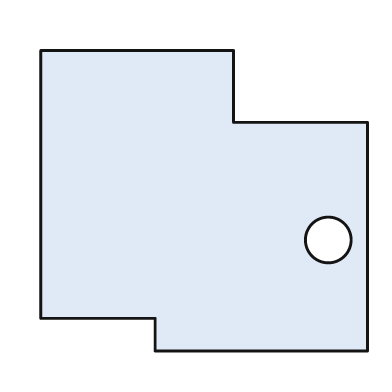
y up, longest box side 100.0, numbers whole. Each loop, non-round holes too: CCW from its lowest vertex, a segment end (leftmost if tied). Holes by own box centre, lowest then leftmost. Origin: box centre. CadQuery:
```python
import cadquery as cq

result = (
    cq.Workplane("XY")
    .moveTo(-15.0, -46.0)
    .lineTo(50.0, -46.0)
    .lineTo(50.0, 24.0)
    .lineTo(9.0, 24.0)
    .lineTo(9.0, 46.0)
    .lineTo(-50.0, 46.0)
    .lineTo(-50.0, -36.0)
    .lineTo(-15.0, -36.0)
    .close()
    .moveTo(38.0, -12.0)
    .circle(7.0)
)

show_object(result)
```